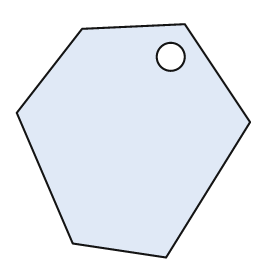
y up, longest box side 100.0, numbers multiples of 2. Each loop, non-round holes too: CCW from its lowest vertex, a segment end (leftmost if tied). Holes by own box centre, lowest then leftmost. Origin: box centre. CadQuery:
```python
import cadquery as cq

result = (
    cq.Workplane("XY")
    .moveTo(14.0, -50.0)
    .lineTo(50.0, 8.0)
    .lineTo(22.0, 50.0)
    .lineTo(-22.0, 48.0)
    .lineTo(-50.0, 12.0)
    .lineTo(-26.0, -44.0)
    .close()
    .moveTo(16.0, 36.0)
    .circle(6.0)
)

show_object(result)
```